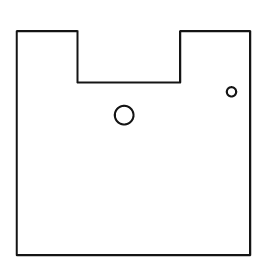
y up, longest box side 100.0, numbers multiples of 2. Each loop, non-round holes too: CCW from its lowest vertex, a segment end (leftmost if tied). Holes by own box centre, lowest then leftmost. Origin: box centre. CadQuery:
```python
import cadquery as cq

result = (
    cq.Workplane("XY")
    .moveTo(-50.0, -48.0)
    .lineTo(50.0, -48.0)
    .lineTo(50.0, 48.0)
    .lineTo(20.0, 48.0)
    .lineTo(20.0, 26.0)
    .lineTo(-24.0, 26.0)
    .lineTo(-24.0, 48.0)
    .lineTo(-50.0, 48.0)
    .close()
    .moveTo(-4.0, 12.0)
    .circle(4.0)
    .moveTo(42.0, 22.0)
    .circle(2.0)
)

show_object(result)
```